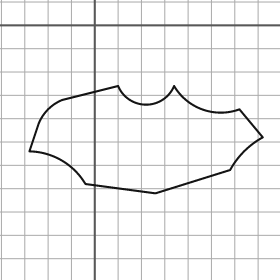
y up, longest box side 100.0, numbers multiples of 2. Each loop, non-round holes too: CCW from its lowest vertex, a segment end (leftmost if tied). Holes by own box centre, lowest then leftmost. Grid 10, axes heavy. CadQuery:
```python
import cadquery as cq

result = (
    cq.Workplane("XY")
    .moveTo(26.0, -72.0)
    .lineTo(58.0, -62.0)
    .threePointArc((64.0, -54.0), (72.0, -48.0))
    .lineTo(62.0, -36.0)
    .threePointArc((46.0, -36.0), (34.0, -26.0))
    .threePointArc((22.0, -34.0), (10.0, -26.0))
    .lineTo(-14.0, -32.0)
    .threePointArc((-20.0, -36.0), (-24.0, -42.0))
    .lineTo(-28.0, -54.0)
    .threePointArc((-14.0, -58.0), (-4.0, -68.0))
    .close()
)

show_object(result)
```